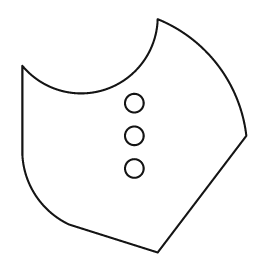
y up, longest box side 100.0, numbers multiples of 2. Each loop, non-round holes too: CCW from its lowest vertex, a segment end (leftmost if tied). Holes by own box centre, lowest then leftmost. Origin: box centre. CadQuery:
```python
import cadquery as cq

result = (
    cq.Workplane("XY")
    .moveTo(10.0, -50.0)
    .lineTo(48.0, 0.0)
    .threePointArc((36.0, 30.0), (10.0, 50.0))
    .threePointArc((-12.0, 20.0), (-48.0, 30.0))
    .lineTo(-48.0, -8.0)
    .threePointArc((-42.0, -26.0), (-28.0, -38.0))
    .close()
    .moveTo(0.0, -14.0)
    .circle(4.0)
    .moveTo(0.0, 0.0)
    .circle(4.0)
    .moveTo(0.0, 14.0)
    .circle(4.0)
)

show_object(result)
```